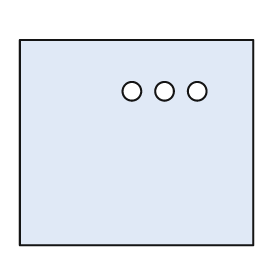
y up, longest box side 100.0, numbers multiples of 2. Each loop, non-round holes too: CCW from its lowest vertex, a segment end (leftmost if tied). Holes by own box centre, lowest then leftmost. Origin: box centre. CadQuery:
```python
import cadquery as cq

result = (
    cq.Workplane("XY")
    .moveTo(-50.0, -44.0)
    .lineTo(50.0, -44.0)
    .lineTo(50.0, 44.0)
    .lineTo(-50.0, 44.0)
    .close()
    .moveTo(-2.0, 22.0)
    .circle(4.0)
    .moveTo(12.0, 22.0)
    .circle(4.0)
    .moveTo(26.0, 22.0)
    .circle(4.0)
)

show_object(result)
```